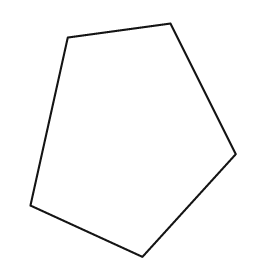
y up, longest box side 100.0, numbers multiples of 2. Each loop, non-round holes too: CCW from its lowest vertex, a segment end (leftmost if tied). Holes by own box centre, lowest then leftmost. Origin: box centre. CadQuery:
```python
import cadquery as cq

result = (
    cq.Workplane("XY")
    .moveTo(4.0, -50.0)
    .lineTo(44.0, -6.0)
    .lineTo(16.0, 50.0)
    .lineTo(-28.0, 44.0)
    .lineTo(-44.0, -28.0)
    .close()
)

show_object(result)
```